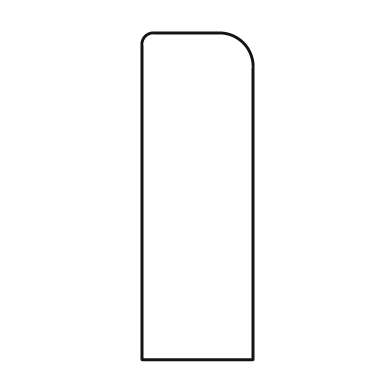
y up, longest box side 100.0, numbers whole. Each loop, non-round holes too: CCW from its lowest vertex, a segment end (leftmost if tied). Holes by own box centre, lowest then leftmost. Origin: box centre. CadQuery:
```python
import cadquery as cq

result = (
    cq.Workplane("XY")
    .moveTo(-17.0, -50.0)
    .lineTo(17.0, -50.0)
    .lineTo(17.0, 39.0)
    .threePointArc((14.0, 47.0), (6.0, 50.0))
    .lineTo(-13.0, 50.0)
    .threePointArc((-16.0, 49.0), (-17.0, 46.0))
    .close()
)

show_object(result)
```